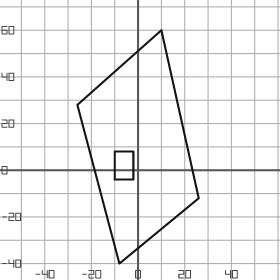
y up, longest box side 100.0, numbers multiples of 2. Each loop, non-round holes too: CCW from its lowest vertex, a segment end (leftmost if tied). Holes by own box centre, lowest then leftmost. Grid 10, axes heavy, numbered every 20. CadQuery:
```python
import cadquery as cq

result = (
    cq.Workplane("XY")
    .moveTo(-8.0, -40.0)
    .lineTo(26.0, -12.0)
    .lineTo(10.0, 60.0)
    .lineTo(-26.0, 28.0)
    .close()
    .moveTo(-10.0, -4.0)
    .lineTo(-2.0, -4.0)
    .lineTo(-2.0, 8.0)
    .lineTo(-10.0, 8.0)
    .close()
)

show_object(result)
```